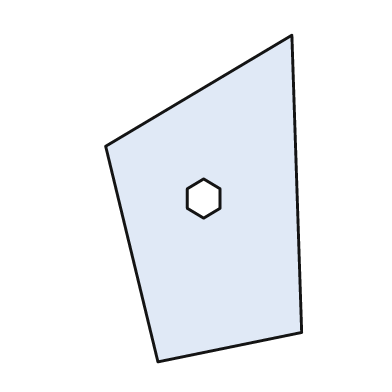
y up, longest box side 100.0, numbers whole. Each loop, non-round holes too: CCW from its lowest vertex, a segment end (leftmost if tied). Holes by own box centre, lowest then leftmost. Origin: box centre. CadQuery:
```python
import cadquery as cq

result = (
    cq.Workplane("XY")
    .moveTo(-14.0, -50.0)
    .lineTo(30.0, -41.0)
    .lineTo(27.0, 50.0)
    .lineTo(-30.0, 16.0)
    .close()
    .moveTo(0.0, -6.0)
    .lineTo(5.0, -3.0)
    .lineTo(5.0, 3.0)
    .lineTo(0.0, 6.0)
    .lineTo(-5.0, 3.0)
    .lineTo(-5.0, -3.0)
    .close()
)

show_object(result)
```